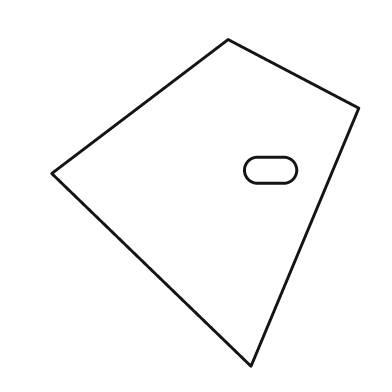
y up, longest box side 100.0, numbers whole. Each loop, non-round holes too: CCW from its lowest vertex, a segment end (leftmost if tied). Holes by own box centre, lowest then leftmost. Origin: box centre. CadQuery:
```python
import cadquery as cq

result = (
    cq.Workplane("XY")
    .moveTo(14.0, -50.0)
    .lineTo(47.0, 29.0)
    .lineTo(7.0, 50.0)
    .lineTo(-47.0, 9.0)
    .close()
    .moveTo(16.0, 6.0)
    .lineTo(24.0, 6.0)
    .threePointArc((28.0, 10.0), (24.0, 14.0))
    .lineTo(16.0, 14.0)
    .threePointArc((12.0, 10.0), (16.0, 6.0))
    .close()
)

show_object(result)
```